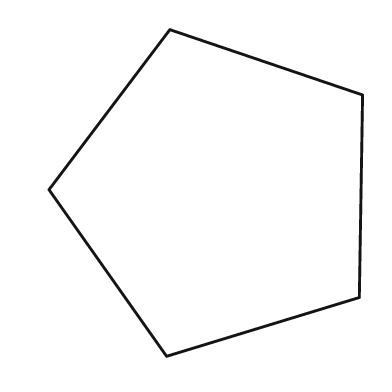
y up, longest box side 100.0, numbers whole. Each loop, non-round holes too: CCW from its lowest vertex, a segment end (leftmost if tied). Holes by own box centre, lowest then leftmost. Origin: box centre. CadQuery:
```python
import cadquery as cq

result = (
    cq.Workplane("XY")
    .moveTo(-12.0, -50.0)
    .lineTo(47.0, -32.0)
    .lineTo(48.0, 30.0)
    .lineTo(-11.0, 50.0)
    .lineTo(-48.0, 1.0)
    .close()
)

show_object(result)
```